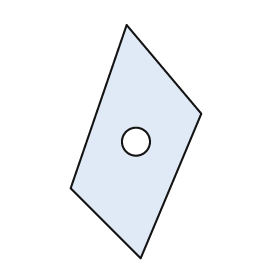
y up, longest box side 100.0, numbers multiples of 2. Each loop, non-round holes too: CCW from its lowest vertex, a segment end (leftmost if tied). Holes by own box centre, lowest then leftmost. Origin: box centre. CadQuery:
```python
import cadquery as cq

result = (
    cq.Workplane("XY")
    .moveTo(2.0, -50.0)
    .lineTo(28.0, 12.0)
    .lineTo(-4.0, 50.0)
    .lineTo(-28.0, -20.0)
    .close()
    .moveTo(0.0, 0.0)
    .circle(6.0)
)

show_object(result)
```